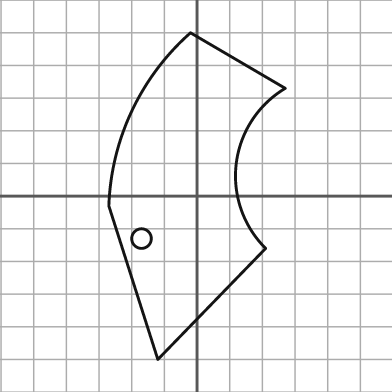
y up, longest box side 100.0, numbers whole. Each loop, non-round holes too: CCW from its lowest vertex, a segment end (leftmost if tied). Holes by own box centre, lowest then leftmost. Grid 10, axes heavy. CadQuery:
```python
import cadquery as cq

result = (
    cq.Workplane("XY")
    .moveTo(-12.0, -50.0)
    .lineTo(21.0, -16.0)
    .threePointArc((12.0, 10.0), (27.0, 33.0))
    .lineTo(-2.0, 50.0)
    .threePointArc((-20.0, 26.0), (-27.0, -3.0))
    .close()
    .moveTo(-17.0, -13.0)
    .circle(3.0)
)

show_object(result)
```